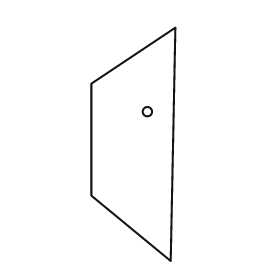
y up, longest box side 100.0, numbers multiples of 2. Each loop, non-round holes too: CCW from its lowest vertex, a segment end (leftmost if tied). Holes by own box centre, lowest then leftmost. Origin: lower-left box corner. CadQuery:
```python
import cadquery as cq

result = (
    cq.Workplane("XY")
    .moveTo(34.0, 0.0)
    .lineTo(36.0, 100.0)
    .lineTo(0.0, 76.0)
    .lineTo(0.0, 28.0)
    .close()
    .moveTo(24.0, 64.0)
    .circle(2.0)
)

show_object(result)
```